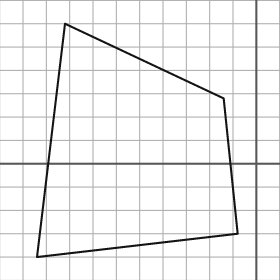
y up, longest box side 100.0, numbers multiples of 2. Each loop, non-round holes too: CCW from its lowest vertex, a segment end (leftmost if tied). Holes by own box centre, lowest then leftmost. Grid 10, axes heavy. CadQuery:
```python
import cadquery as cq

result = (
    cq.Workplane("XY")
    .moveTo(-94.0, -40.0)
    .lineTo(-8.0, -30.0)
    .lineTo(-14.0, 28.0)
    .lineTo(-82.0, 60.0)
    .close()
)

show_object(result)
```